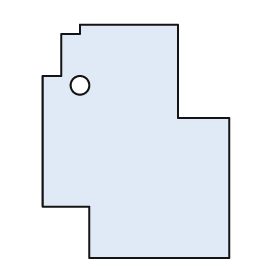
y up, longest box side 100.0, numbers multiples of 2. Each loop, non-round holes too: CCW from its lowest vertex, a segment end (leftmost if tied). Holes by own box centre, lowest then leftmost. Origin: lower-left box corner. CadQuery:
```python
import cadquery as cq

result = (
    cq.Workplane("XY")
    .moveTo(20.0, 0.0)
    .lineTo(80.0, 0.0)
    .lineTo(80.0, 60.0)
    .lineTo(58.0, 60.0)
    .lineTo(58.0, 100.0)
    .lineTo(16.0, 100.0)
    .lineTo(16.0, 96.0)
    .lineTo(8.0, 96.0)
    .lineTo(8.0, 78.0)
    .lineTo(0.0, 78.0)
    .lineTo(0.0, 22.0)
    .lineTo(20.0, 22.0)
    .close()
    .moveTo(16.0, 74.0)
    .circle(4.0)
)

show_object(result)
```